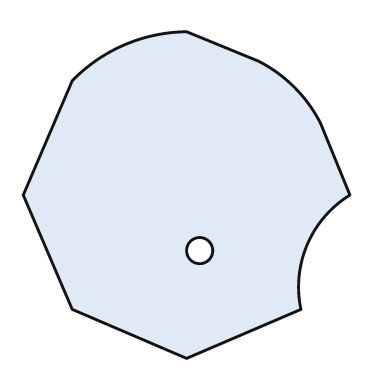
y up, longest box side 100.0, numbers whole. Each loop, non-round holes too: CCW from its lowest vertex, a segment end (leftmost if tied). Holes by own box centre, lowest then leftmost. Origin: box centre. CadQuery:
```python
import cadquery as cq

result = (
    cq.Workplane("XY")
    .moveTo(0.0, -50.0)
    .lineTo(35.0, -35.0)
    .threePointArc((37.0, -15.0), (50.0, 0.0))
    .lineTo(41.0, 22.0)
    .threePointArc((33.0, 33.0), (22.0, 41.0))
    .lineTo(0.0, 50.0)
    .threePointArc((-19.0, 46.0), (-35.0, 35.0))
    .lineTo(-50.0, 0.0)
    .lineTo(-35.0, -35.0)
    .close()
    .moveTo(4.0, -17.0)
    .circle(4.0)
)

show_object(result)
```